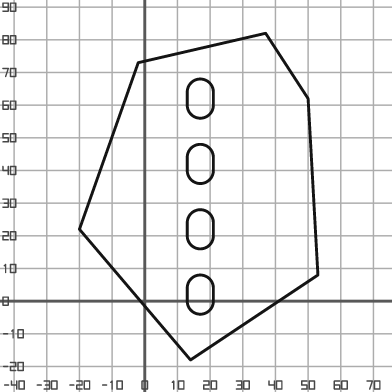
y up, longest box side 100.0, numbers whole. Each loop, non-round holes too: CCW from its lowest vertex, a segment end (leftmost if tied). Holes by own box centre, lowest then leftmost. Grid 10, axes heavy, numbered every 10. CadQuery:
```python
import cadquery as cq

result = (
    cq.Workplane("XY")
    .moveTo(14.0, -18.0)
    .lineTo(53.0, 8.0)
    .lineTo(50.0, 62.0)
    .lineTo(37.0, 82.0)
    .lineTo(-2.0, 73.0)
    .lineTo(-20.0, 22.0)
    .close()
    .moveTo(13.0, 0.0)
    .threePointArc((17.0, -4.0), (21.0, 0.0))
    .lineTo(21.0, 4.0)
    .threePointArc((17.0, 8.0), (13.0, 4.0))
    .close()
    .moveTo(13.0, 20.0)
    .threePointArc((17.0, 16.0), (21.0, 20.0))
    .lineTo(21.0, 24.0)
    .threePointArc((17.0, 28.0), (13.0, 24.0))
    .close()
    .moveTo(13.0, 40.0)
    .threePointArc((17.0, 36.0), (21.0, 40.0))
    .lineTo(21.0, 44.0)
    .threePointArc((17.0, 48.0), (13.0, 44.0))
    .close()
    .moveTo(13.0, 60.0)
    .threePointArc((17.0, 56.0), (21.0, 60.0))
    .lineTo(21.0, 64.0)
    .threePointArc((17.0, 68.0), (13.0, 64.0))
    .close()
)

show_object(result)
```